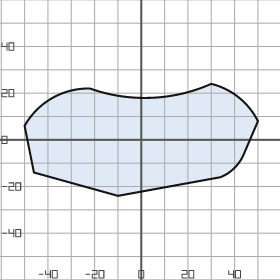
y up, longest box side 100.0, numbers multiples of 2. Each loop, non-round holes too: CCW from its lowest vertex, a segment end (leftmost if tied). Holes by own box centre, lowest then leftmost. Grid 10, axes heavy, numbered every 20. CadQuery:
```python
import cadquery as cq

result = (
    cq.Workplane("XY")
    .moveTo(-10.0, -24.0)
    .lineTo(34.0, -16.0)
    .threePointArc((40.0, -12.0), (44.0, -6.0))
    .lineTo(50.0, 8.0)
    .threePointArc((42.0, 18.0), (30.0, 24.0))
    .threePointArc((4.0, 18.0), (-22.0, 22.0))
    .threePointArc((-38.0, 18.0), (-50.0, 6.0))
    .lineTo(-46.0, -14.0)
    .close()
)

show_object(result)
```